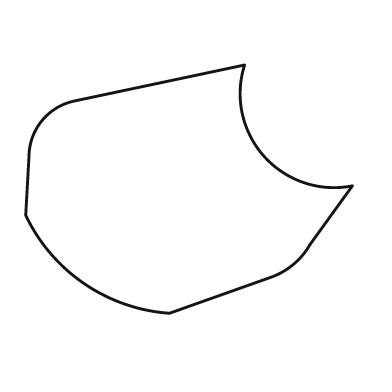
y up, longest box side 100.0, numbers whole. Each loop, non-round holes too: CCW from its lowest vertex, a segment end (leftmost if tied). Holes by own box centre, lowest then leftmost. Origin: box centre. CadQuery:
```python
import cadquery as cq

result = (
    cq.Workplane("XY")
    .moveTo(-6.0, -38.0)
    .lineTo(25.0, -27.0)
    .threePointArc((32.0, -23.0), (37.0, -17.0))
    .lineTo(50.0, 1.0)
    .threePointArc((23.0, 10.0), (17.0, 38.0))
    .lineTo(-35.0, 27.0)
    .threePointArc((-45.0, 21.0), (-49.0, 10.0))
    .lineTo(-50.0, -8.0)
    .threePointArc((-32.0, -29.0), (-6.0, -38.0))
    .close()
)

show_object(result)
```